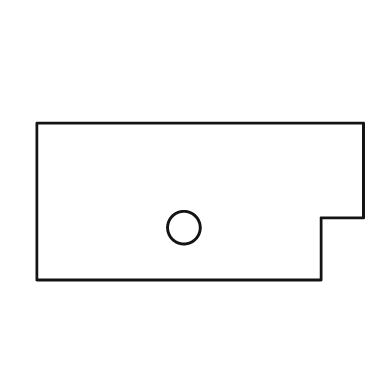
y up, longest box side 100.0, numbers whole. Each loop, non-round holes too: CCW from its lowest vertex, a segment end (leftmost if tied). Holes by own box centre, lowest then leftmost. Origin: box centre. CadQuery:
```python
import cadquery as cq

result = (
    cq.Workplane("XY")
    .moveTo(-50.0, -24.0)
    .lineTo(37.0, -24.0)
    .lineTo(37.0, -5.0)
    .lineTo(50.0, -5.0)
    .lineTo(50.0, 24.0)
    .lineTo(-50.0, 24.0)
    .close()
    .moveTo(-5.0, -8.0)
    .circle(5.0)
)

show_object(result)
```